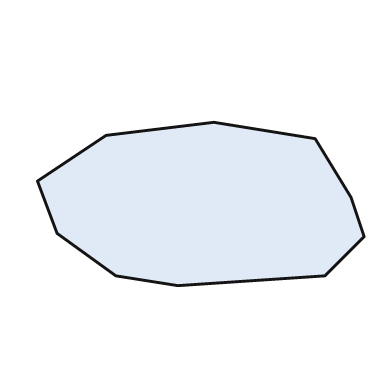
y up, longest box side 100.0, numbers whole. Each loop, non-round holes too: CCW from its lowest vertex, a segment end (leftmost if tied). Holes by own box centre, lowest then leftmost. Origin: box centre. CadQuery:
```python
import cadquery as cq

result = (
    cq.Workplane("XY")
    .moveTo(-7.0, -25.0)
    .lineTo(38.0, -22.0)
    .lineTo(50.0, -10.0)
    .lineTo(46.0, 2.0)
    .lineTo(35.0, 20.0)
    .lineTo(4.0, 25.0)
    .lineTo(-29.0, 21.0)
    .lineTo(-50.0, 7.0)
    .lineTo(-44.0, -9.0)
    .lineTo(-26.0, -22.0)
    .close()
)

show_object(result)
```